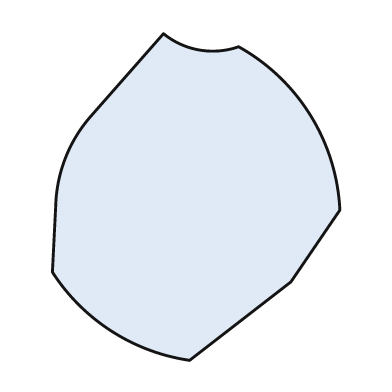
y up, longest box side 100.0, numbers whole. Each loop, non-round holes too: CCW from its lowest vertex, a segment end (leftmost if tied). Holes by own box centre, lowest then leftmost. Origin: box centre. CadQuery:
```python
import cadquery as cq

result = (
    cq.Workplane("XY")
    .moveTo(-2.0, -50.0)
    .lineTo(29.0, -26.0)
    .lineTo(44.0, -4.0)
    .threePointArc((35.0, 25.0), (13.0, 46.0))
    .threePointArc((1.0, 45.0), (-10.0, 50.0))
    .lineTo(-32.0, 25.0)
    .threePointArc((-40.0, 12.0), (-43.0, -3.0))
    .lineTo(-44.0, -23.0)
    .threePointArc((-26.0, -41.0), (-2.0, -50.0))
    .close()
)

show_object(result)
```